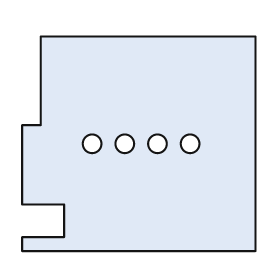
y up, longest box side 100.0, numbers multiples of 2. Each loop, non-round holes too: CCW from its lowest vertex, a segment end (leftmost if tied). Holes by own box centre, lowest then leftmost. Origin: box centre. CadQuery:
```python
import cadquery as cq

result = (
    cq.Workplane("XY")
    .moveTo(-50.0, -46.0)
    .lineTo(50.0, -46.0)
    .lineTo(50.0, 46.0)
    .lineTo(-42.0, 46.0)
    .lineTo(-42.0, 8.0)
    .lineTo(-50.0, 8.0)
    .lineTo(-50.0, -26.0)
    .lineTo(-32.0, -26.0)
    .lineTo(-32.0, -40.0)
    .lineTo(-50.0, -40.0)
    .close()
    .moveTo(-20.0, 0.0)
    .circle(4.0)
    .moveTo(-6.0, 0.0)
    .circle(4.0)
    .moveTo(8.0, 0.0)
    .circle(4.0)
    .moveTo(22.0, 0.0)
    .circle(4.0)
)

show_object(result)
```